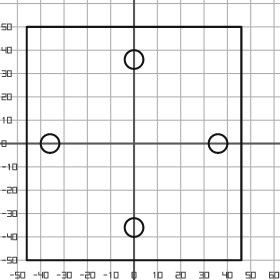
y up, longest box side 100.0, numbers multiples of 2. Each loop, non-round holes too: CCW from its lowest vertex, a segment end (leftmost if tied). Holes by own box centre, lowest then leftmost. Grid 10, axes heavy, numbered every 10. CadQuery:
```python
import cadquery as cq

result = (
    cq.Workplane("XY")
    .moveTo(-46.0, -50.0)
    .lineTo(46.0, -50.0)
    .lineTo(46.0, 50.0)
    .lineTo(-46.0, 50.0)
    .close()
    .moveTo(0.0, -36.0)
    .circle(4.0)
    .moveTo(-36.0, 0.0)
    .circle(4.0)
    .moveTo(36.0, 0.0)
    .circle(4.0)
    .moveTo(0.0, 36.0)
    .circle(4.0)
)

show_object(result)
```